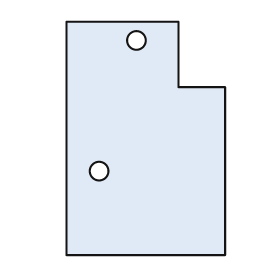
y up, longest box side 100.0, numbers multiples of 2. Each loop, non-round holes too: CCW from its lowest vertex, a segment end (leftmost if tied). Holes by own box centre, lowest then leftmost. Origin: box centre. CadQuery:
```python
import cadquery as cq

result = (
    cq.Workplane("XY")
    .moveTo(-34.0, -50.0)
    .lineTo(34.0, -50.0)
    .lineTo(34.0, 22.0)
    .lineTo(14.0, 22.0)
    .lineTo(14.0, 50.0)
    .lineTo(-34.0, 50.0)
    .close()
    .moveTo(-20.0, -14.0)
    .circle(4.0)
    .moveTo(-4.0, 42.0)
    .circle(4.0)
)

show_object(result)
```